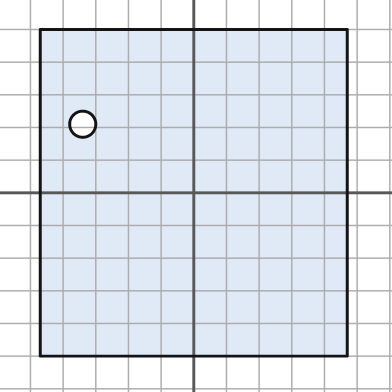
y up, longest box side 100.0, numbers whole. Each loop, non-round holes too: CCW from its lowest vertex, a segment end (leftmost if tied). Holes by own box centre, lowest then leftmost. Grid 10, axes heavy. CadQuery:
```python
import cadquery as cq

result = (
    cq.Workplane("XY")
    .moveTo(-47.0, -50.0)
    .lineTo(47.0, -50.0)
    .lineTo(47.0, 50.0)
    .lineTo(-47.0, 50.0)
    .close()
    .moveTo(-34.0, 21.0)
    .circle(4.0)
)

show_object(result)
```